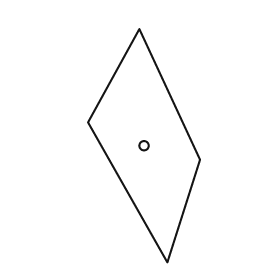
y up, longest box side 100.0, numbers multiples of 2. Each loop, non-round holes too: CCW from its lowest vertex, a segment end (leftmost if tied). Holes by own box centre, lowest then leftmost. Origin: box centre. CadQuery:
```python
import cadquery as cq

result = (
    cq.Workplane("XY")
    .moveTo(10.0, -50.0)
    .lineTo(24.0, -6.0)
    .lineTo(-2.0, 50.0)
    .lineTo(-24.0, 10.0)
    .close()
    .moveTo(0.0, 0.0)
    .circle(2.0)
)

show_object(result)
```